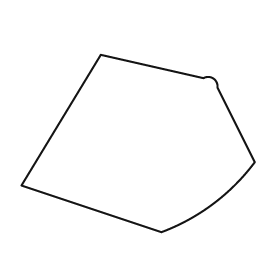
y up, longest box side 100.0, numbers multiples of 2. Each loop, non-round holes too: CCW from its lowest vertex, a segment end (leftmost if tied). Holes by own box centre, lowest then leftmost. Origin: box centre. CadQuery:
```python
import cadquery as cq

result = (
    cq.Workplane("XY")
    .moveTo(10.0, -38.0)
    .threePointArc((32.0, -26.0), (50.0, -8.0))
    .lineTo(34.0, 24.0)
    .threePointArc((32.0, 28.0), (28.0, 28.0))
    .lineTo(-16.0, 38.0)
    .lineTo(-50.0, -18.0)
    .close()
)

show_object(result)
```